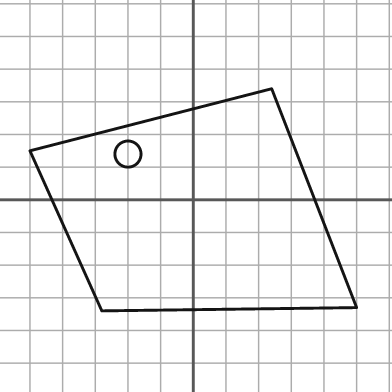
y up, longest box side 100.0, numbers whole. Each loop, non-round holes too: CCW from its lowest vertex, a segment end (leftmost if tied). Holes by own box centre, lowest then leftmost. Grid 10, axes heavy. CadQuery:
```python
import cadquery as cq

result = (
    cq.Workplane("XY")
    .moveTo(-28.0, -34.0)
    .lineTo(50.0, -33.0)
    .lineTo(24.0, 34.0)
    .lineTo(-50.0, 15.0)
    .close()
    .moveTo(-20.0, 14.0)
    .circle(4.0)
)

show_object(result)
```